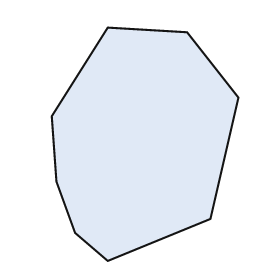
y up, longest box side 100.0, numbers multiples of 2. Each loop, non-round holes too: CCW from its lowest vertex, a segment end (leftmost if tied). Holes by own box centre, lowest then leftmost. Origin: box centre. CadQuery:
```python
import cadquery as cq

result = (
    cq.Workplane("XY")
    .moveTo(-16.0, -50.0)
    .lineTo(28.0, -32.0)
    .lineTo(40.0, 20.0)
    .lineTo(18.0, 48.0)
    .lineTo(-16.0, 50.0)
    .lineTo(-40.0, 12.0)
    .lineTo(-38.0, -16.0)
    .lineTo(-30.0, -38.0)
    .close()
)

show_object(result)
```